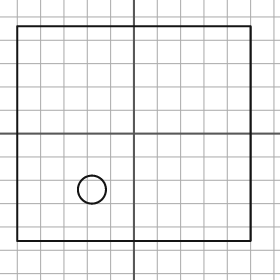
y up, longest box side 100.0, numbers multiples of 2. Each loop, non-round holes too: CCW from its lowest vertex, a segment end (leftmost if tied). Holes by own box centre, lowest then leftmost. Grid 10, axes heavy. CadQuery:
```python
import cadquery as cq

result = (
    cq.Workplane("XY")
    .moveTo(-50.0, -46.0)
    .lineTo(50.0, -46.0)
    .lineTo(50.0, 46.0)
    .lineTo(-50.0, 46.0)
    .close()
    .moveTo(-18.0, -24.0)
    .circle(6.0)
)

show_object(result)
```